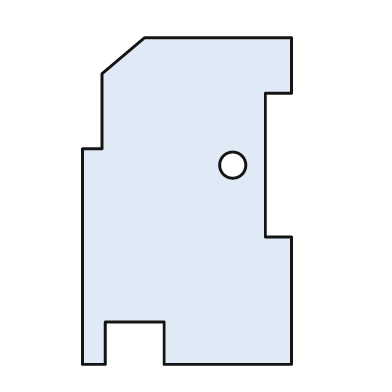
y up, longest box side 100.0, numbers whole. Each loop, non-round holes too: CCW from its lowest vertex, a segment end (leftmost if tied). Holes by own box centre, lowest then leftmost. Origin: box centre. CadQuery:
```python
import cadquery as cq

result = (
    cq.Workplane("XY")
    .moveTo(-32.0, -50.0)
    .lineTo(-25.0, -50.0)
    .lineTo(-25.0, -37.0)
    .lineTo(-7.0, -37.0)
    .lineTo(-7.0, -50.0)
    .lineTo(32.0, -50.0)
    .lineTo(32.0, -11.0)
    .lineTo(24.0, -11.0)
    .lineTo(24.0, 33.0)
    .lineTo(32.0, 33.0)
    .lineTo(32.0, 50.0)
    .lineTo(-13.0, 50.0)
    .lineTo(-26.0, 39.0)
    .lineTo(-26.0, 16.0)
    .lineTo(-32.0, 16.0)
    .close()
    .moveTo(14.0, 11.0)
    .circle(4.0)
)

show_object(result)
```